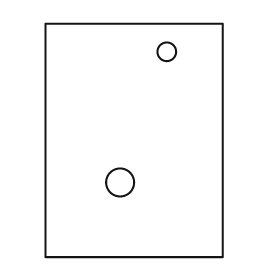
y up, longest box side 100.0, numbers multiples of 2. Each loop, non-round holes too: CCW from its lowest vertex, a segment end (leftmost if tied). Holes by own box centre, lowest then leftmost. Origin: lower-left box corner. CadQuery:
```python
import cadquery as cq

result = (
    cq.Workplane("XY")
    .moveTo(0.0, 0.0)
    .lineTo(76.0, 0.0)
    .lineTo(76.0, 100.0)
    .lineTo(0.0, 100.0)
    .close()
    .moveTo(32.0, 32.0)
    .circle(6.0)
    .moveTo(52.0, 88.0)
    .circle(4.0)
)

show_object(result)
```